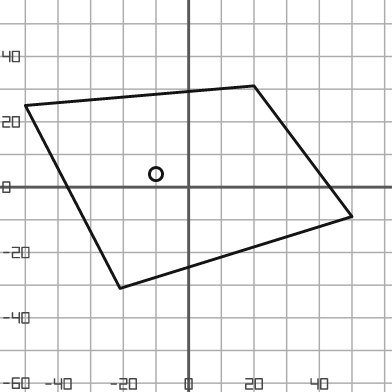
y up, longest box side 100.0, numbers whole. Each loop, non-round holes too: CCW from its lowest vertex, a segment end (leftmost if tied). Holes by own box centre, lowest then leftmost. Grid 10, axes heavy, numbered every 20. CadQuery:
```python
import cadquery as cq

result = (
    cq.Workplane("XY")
    .moveTo(-21.0, -31.0)
    .lineTo(50.0, -9.0)
    .lineTo(20.0, 31.0)
    .lineTo(-50.0, 25.0)
    .close()
    .moveTo(-10.0, 4.0)
    .circle(2.0)
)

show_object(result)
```